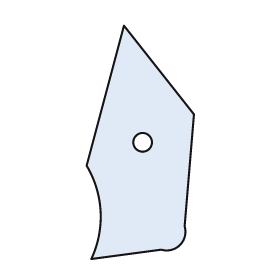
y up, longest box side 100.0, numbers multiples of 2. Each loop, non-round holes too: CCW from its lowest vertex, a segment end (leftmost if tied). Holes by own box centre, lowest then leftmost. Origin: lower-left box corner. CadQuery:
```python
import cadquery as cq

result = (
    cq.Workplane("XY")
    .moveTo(2.0, 0.0)
    .lineTo(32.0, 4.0)
    .threePointArc((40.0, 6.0), (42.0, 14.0))
    .lineTo(46.0, 62.0)
    .lineTo(16.0, 100.0)
    .lineTo(0.0, 40.0)
    .threePointArc((6.0, 20.0), (2.0, 0.0))
    .close()
    .moveTo(24.0, 50.0)
    .circle(4.0)
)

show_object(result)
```